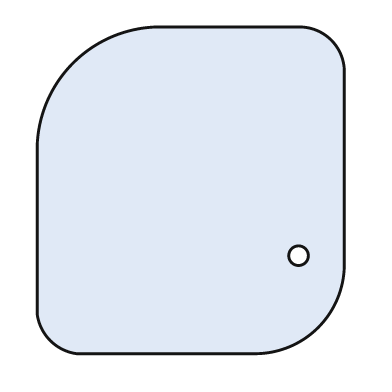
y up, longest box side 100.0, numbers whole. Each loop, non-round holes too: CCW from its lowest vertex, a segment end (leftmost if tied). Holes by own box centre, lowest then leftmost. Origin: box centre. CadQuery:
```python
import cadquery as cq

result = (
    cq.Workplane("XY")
    .moveTo(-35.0, -50.0)
    .lineTo(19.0, -50.0)
    .threePointArc((39.0, -42.0), (47.0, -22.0))
    .lineTo(47.0, 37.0)
    .threePointArc((43.0, 46.0), (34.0, 50.0))
    .lineTo(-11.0, 50.0)
    .threePointArc((-36.0, 39.0), (-47.0, 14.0))
    .lineTo(-47.0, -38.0)
    .threePointArc((-43.0, -46.0), (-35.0, -50.0))
    .close()
    .moveTo(33.0, -20.0)
    .circle(3.0)
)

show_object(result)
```